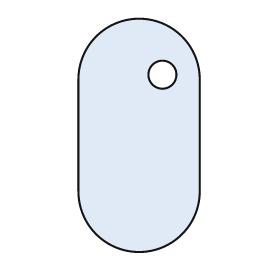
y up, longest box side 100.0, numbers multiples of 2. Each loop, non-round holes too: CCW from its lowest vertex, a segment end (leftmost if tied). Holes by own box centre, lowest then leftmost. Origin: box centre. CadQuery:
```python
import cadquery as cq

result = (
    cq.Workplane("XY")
    .moveTo(-26.0, -24.0)
    .threePointArc((0.0, -50.0), (26.0, -24.0))
    .lineTo(26.0, 24.0)
    .threePointArc((0.0, 50.0), (-26.0, 24.0))
    .close()
    .moveTo(10.0, 26.0)
    .circle(6.0)
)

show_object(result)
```